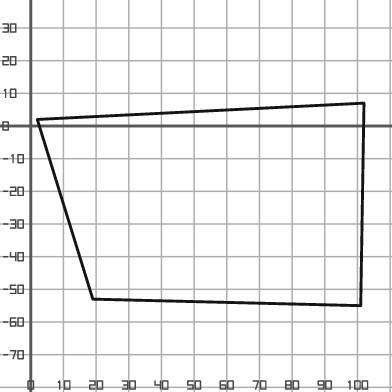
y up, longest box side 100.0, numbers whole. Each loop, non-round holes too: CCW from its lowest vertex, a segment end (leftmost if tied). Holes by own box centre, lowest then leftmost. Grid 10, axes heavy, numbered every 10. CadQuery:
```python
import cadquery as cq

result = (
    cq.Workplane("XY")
    .moveTo(101.0, -55.0)
    .lineTo(102.0, 7.0)
    .lineTo(2.0, 2.0)
    .lineTo(19.0, -53.0)
    .close()
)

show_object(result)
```